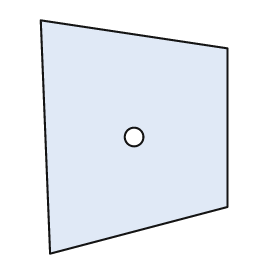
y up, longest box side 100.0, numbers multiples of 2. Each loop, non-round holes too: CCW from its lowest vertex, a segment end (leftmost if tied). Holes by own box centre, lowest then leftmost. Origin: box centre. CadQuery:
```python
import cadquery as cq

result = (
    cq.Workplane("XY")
    .moveTo(-36.0, -50.0)
    .lineTo(40.0, -30.0)
    .lineTo(40.0, 38.0)
    .lineTo(-40.0, 50.0)
    .close()
    .moveTo(0.0, 0.0)
    .circle(4.0)
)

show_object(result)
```